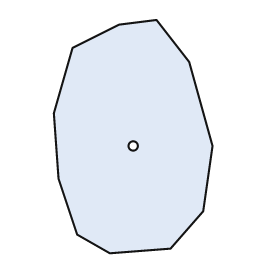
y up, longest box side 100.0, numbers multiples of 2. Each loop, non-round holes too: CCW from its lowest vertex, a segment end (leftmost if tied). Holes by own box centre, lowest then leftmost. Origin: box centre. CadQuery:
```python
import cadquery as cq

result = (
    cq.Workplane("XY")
    .moveTo(-10.0, -50.0)
    .lineTo(16.0, -48.0)
    .lineTo(30.0, -32.0)
    .lineTo(34.0, -4.0)
    .lineTo(24.0, 32.0)
    .lineTo(10.0, 50.0)
    .lineTo(-6.0, 48.0)
    .lineTo(-26.0, 38.0)
    .lineTo(-34.0, 10.0)
    .lineTo(-32.0, -18.0)
    .lineTo(-24.0, -42.0)
    .close()
    .moveTo(0.0, -4.0)
    .circle(2.0)
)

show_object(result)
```